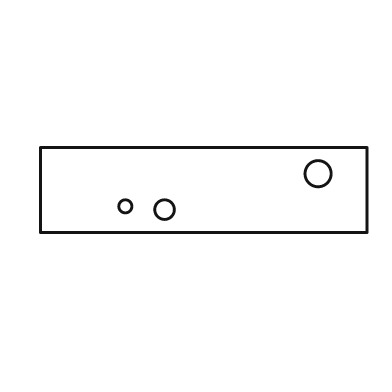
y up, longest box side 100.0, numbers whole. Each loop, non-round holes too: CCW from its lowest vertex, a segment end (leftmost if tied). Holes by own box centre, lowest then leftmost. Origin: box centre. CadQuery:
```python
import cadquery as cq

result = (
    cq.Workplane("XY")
    .moveTo(-50.0, -13.0)
    .lineTo(50.0, -13.0)
    .lineTo(50.0, 13.0)
    .lineTo(-50.0, 13.0)
    .close()
    .moveTo(-12.0, -6.0)
    .circle(3.0)
    .moveTo(-24.0, -5.0)
    .circle(2.0)
    .moveTo(35.0, 5.0)
    .circle(4.0)
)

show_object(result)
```